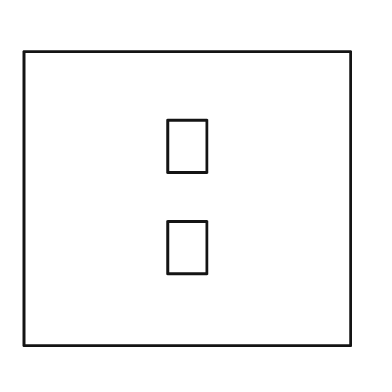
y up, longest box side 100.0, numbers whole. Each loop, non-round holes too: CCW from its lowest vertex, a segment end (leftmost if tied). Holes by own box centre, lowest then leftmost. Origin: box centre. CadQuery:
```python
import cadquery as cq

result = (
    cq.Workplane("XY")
    .moveTo(-50.0, -45.0)
    .lineTo(50.0, -45.0)
    .lineTo(50.0, 45.0)
    .lineTo(-50.0, 45.0)
    .close()
    .moveTo(-6.0, -23.0)
    .lineTo(6.0, -23.0)
    .lineTo(6.0, -7.0)
    .lineTo(-6.0, -7.0)
    .close()
    .moveTo(-6.0, 8.0)
    .lineTo(6.0, 8.0)
    .lineTo(6.0, 24.0)
    .lineTo(-6.0, 24.0)
    .close()
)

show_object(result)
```